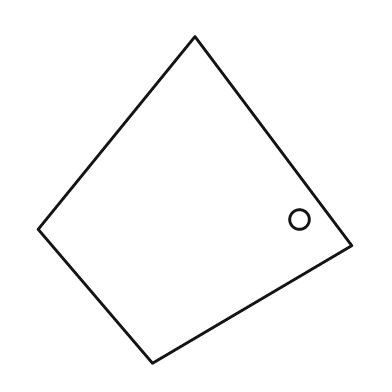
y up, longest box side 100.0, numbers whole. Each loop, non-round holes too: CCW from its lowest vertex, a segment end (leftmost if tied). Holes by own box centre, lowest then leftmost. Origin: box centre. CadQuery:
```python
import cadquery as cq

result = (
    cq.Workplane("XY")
    .moveTo(-13.0, -50.0)
    .lineTo(48.0, -14.0)
    .lineTo(0.0, 50.0)
    .lineTo(-48.0, -9.0)
    .close()
    .moveTo(32.0, -6.0)
    .circle(3.0)
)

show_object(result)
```